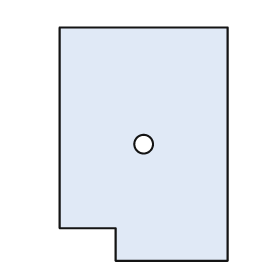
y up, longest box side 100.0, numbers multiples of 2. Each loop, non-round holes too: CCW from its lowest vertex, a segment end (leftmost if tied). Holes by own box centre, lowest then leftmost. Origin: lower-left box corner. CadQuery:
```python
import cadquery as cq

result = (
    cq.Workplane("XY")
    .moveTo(24.0, 0.0)
    .lineTo(72.0, 0.0)
    .lineTo(72.0, 100.0)
    .lineTo(0.0, 100.0)
    .lineTo(0.0, 14.0)
    .lineTo(24.0, 14.0)
    .close()
    .moveTo(36.0, 50.0)
    .circle(4.0)
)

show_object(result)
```